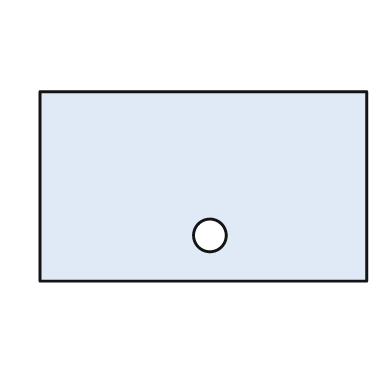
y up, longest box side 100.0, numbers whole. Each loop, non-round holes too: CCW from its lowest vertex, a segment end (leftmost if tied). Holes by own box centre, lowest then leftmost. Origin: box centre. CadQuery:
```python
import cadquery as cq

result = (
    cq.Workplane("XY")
    .moveTo(-50.0, -29.0)
    .lineTo(50.0, -29.0)
    .lineTo(50.0, 29.0)
    .lineTo(-50.0, 29.0)
    .close()
    .moveTo(2.0, -15.0)
    .circle(5.0)
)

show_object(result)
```